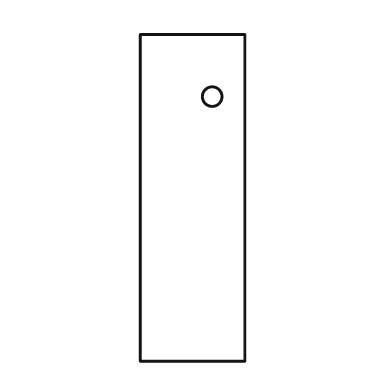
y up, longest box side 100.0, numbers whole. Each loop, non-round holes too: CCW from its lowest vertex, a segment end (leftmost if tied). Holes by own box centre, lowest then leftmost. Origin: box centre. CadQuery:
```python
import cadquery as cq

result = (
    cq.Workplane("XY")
    .moveTo(-16.0, -50.0)
    .lineTo(16.0, -50.0)
    .lineTo(16.0, 50.0)
    .lineTo(-16.0, 50.0)
    .close()
    .moveTo(6.0, 31.0)
    .circle(3.0)
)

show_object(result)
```